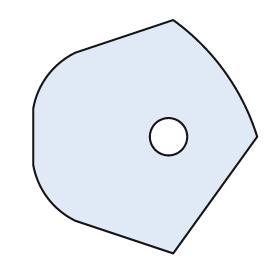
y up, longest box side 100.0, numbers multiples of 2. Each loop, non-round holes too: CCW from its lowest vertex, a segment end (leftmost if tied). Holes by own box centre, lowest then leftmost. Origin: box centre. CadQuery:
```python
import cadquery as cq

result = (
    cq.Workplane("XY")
    .moveTo(12.0, -50.0)
    .lineTo(48.0, 0.0)
    .threePointArc((34.0, 28.0), (12.0, 50.0))
    .lineTo(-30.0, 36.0)
    .threePointArc((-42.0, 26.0), (-48.0, 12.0))
    .lineTo(-48.0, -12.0)
    .threePointArc((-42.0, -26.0), (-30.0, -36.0))
    .close()
    .moveTo(10.0, 0.0)
    .circle(8.0)
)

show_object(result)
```